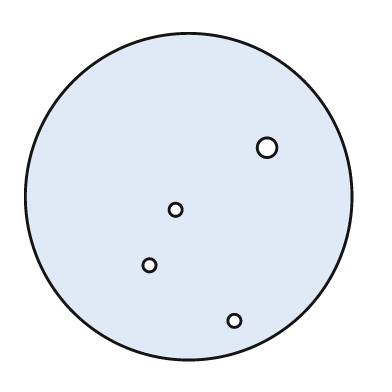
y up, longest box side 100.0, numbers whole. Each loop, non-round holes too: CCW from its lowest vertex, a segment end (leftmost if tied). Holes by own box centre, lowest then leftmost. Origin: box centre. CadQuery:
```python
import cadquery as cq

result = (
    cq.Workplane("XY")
    .moveTo(0.0, 0.0)
    .circle(50.0)
    .moveTo(14.0, -38.0)
    .circle(2.0)
    .moveTo(-12.0, -21.0)
    .circle(2.0)
    .moveTo(-4.0, -4.0)
    .circle(2.0)
    .moveTo(24.0, 15.0)
    .circle(3.0)
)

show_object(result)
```